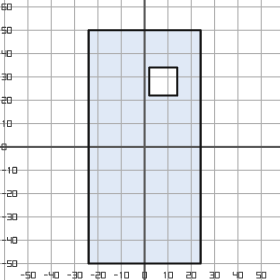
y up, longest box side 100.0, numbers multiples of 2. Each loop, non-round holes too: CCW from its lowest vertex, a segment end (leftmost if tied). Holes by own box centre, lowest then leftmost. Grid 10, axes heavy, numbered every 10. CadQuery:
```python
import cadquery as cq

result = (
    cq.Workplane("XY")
    .moveTo(-24.0, -50.0)
    .lineTo(24.0, -50.0)
    .lineTo(24.0, 50.0)
    .lineTo(-24.0, 50.0)
    .close()
    .moveTo(2.0, 22.0)
    .lineTo(14.0, 22.0)
    .lineTo(14.0, 34.0)
    .lineTo(2.0, 34.0)
    .close()
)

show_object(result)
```